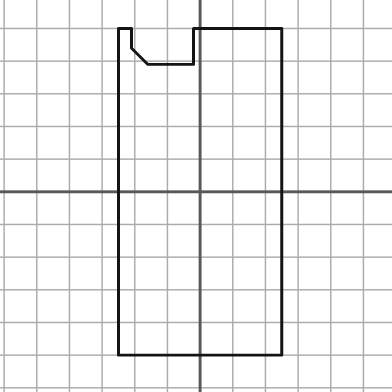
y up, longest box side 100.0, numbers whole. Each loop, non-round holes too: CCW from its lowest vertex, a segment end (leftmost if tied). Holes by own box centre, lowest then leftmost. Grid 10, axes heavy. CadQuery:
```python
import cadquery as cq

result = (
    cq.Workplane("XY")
    .moveTo(-25.0, -50.0)
    .lineTo(25.0, -50.0)
    .lineTo(25.0, 50.0)
    .lineTo(-2.0, 50.0)
    .lineTo(-2.0, 39.0)
    .lineTo(-16.0, 39.0)
    .lineTo(-21.0, 44.0)
    .lineTo(-21.0, 50.0)
    .lineTo(-25.0, 50.0)
    .close()
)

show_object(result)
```